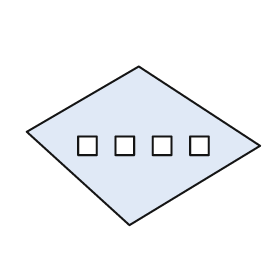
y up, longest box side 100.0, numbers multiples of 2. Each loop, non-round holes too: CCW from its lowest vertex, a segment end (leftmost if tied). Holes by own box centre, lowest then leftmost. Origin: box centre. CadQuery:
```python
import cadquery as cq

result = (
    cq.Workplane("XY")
    .moveTo(-6.0, -34.0)
    .lineTo(50.0, 0.0)
    .lineTo(-2.0, 34.0)
    .lineTo(-50.0, 6.0)
    .close()
    .moveTo(-28.0, -4.0)
    .lineTo(-20.0, -4.0)
    .lineTo(-20.0, 4.0)
    .lineTo(-28.0, 4.0)
    .close()
    .moveTo(-12.0, -4.0)
    .lineTo(-4.0, -4.0)
    .lineTo(-4.0, 4.0)
    .lineTo(-12.0, 4.0)
    .close()
    .moveTo(4.0, -4.0)
    .lineTo(12.0, -4.0)
    .lineTo(12.0, 4.0)
    .lineTo(4.0, 4.0)
    .close()
    .moveTo(20.0, -4.0)
    .lineTo(28.0, -4.0)
    .lineTo(28.0, 4.0)
    .lineTo(20.0, 4.0)
    .close()
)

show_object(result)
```